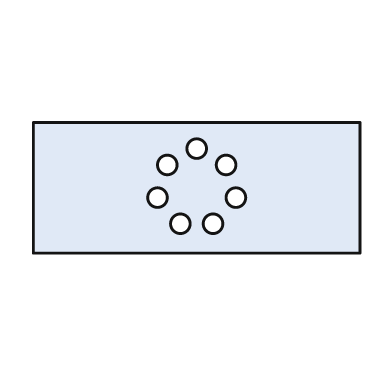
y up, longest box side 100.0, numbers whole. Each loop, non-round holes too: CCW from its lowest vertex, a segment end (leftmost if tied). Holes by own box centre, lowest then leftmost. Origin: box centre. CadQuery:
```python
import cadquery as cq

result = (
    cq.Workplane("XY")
    .moveTo(-50.0, -20.0)
    .lineTo(50.0, -20.0)
    .lineTo(50.0, 20.0)
    .lineTo(-50.0, 20.0)
    .close()
    .moveTo(-5.0, -11.0)
    .circle(3.0)
    .moveTo(5.0, -11.0)
    .circle(3.0)
    .moveTo(-12.0, -3.0)
    .circle(3.0)
    .moveTo(12.0, -3.0)
    .circle(3.0)
    .moveTo(-9.0, 7.0)
    .circle(3.0)
    .moveTo(9.0, 7.0)
    .circle(3.0)
    .moveTo(0.0, 12.0)
    .circle(3.0)
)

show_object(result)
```